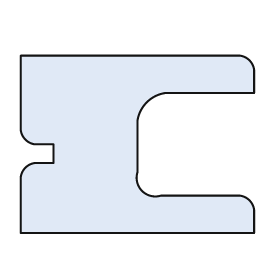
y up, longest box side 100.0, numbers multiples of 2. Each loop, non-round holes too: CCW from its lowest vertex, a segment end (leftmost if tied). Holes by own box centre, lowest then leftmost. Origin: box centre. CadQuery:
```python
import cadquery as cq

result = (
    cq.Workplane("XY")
    .moveTo(-50.0, -38.0)
    .lineTo(50.0, -38.0)
    .lineTo(50.0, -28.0)
    .threePointArc((48.0, -24.0), (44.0, -22.0))
    .lineTo(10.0, -22.0)
    .threePointArc((2.0, -20.0), (0.0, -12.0))
    .lineTo(0.0, 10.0)
    .threePointArc((4.0, 18.0), (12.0, 22.0))
    .lineTo(50.0, 22.0)
    .lineTo(50.0, 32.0)
    .threePointArc((48.0, 36.0), (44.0, 38.0))
    .lineTo(-50.0, 38.0)
    .lineTo(-50.0, 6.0)
    .threePointArc((-48.0, 2.0), (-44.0, 0.0))
    .lineTo(-36.0, 0.0)
    .lineTo(-36.0, -8.0)
    .lineTo(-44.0, -8.0)
    .threePointArc((-48.0, -10.0), (-50.0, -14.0))
    .close()
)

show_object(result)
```